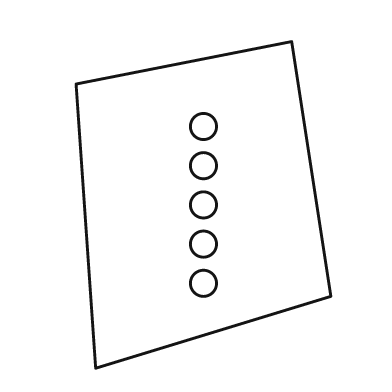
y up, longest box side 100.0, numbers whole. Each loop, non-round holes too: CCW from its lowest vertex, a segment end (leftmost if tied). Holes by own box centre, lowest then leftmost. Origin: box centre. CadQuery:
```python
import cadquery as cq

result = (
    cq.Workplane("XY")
    .moveTo(-33.0, -50.0)
    .lineTo(39.0, -28.0)
    .lineTo(27.0, 50.0)
    .lineTo(-39.0, 37.0)
    .close()
    .moveTo(0.0, -24.0)
    .circle(4.0)
    .moveTo(0.0, -12.0)
    .circle(4.0)
    .moveTo(0.0, 0.0)
    .circle(4.0)
    .moveTo(0.0, 12.0)
    .circle(4.0)
    .moveTo(0.0, 24.0)
    .circle(4.0)
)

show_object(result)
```